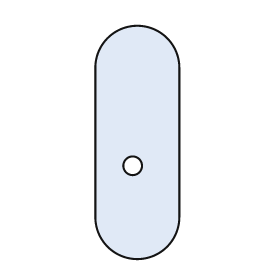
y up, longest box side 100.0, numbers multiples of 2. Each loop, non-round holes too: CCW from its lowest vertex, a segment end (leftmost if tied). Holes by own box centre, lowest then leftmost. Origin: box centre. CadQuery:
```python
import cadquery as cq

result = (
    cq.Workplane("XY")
    .moveTo(-18.0, -32.0)
    .threePointArc((0.0, -50.0), (18.0, -32.0))
    .lineTo(18.0, 32.0)
    .threePointArc((0.0, 50.0), (-18.0, 32.0))
    .close()
    .moveTo(-2.0, -10.0)
    .circle(4.0)
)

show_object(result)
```